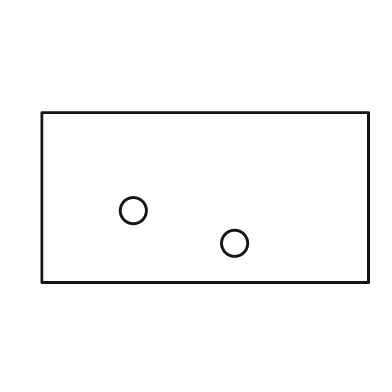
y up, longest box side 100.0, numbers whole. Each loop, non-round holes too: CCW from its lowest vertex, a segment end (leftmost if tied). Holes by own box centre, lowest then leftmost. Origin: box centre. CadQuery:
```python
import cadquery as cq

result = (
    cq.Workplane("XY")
    .moveTo(-50.0, -26.0)
    .lineTo(50.0, -26.0)
    .lineTo(50.0, 26.0)
    .lineTo(-50.0, 26.0)
    .close()
    .moveTo(9.0, -14.0)
    .circle(4.0)
    .moveTo(-22.0, -4.0)
    .circle(4.0)
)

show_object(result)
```